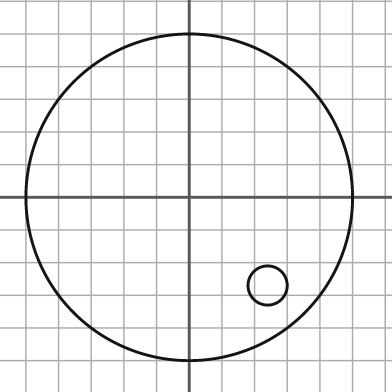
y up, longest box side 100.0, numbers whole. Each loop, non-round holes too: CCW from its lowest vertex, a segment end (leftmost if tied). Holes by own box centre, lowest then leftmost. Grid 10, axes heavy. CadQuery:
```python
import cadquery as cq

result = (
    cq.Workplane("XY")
    .moveTo(0.0, 0.0)
    .circle(50.0)
    .moveTo(24.0, -27.0)
    .circle(6.0)
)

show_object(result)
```